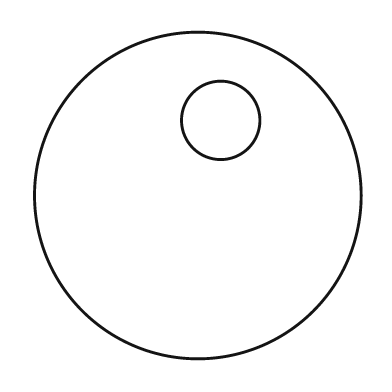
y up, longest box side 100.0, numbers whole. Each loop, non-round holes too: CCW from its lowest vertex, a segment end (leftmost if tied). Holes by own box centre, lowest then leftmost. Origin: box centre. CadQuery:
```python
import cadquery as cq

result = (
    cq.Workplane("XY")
    .moveTo(0.0, 0.0)
    .circle(50.0)
    .moveTo(7.0, 23.0)
    .circle(12.0)
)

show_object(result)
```